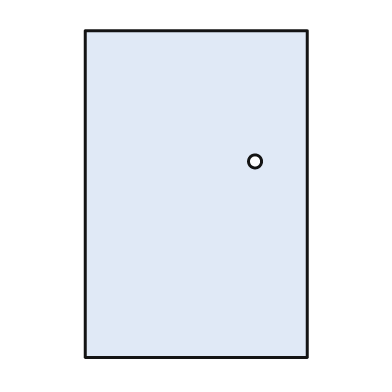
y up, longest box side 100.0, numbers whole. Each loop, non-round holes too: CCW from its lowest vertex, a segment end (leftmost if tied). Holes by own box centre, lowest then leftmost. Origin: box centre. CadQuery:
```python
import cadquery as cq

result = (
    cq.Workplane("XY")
    .moveTo(-34.0, -50.0)
    .lineTo(34.0, -50.0)
    .lineTo(34.0, 50.0)
    .lineTo(-34.0, 50.0)
    .close()
    .moveTo(18.0, 10.0)
    .circle(2.0)
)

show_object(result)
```